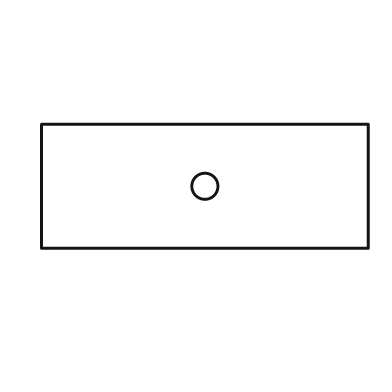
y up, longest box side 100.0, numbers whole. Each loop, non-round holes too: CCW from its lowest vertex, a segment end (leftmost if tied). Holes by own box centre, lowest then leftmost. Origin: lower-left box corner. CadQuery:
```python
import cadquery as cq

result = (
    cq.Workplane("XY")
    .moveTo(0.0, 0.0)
    .lineTo(100.0, 0.0)
    .lineTo(100.0, 38.0)
    .lineTo(0.0, 38.0)
    .close()
    .moveTo(50.0, 19.0)
    .circle(4.0)
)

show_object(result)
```